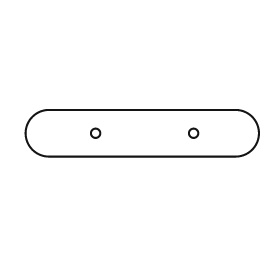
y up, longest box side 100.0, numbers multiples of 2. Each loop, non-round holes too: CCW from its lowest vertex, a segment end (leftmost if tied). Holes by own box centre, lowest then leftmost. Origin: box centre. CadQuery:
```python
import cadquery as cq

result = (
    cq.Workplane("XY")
    .moveTo(-40.0, -10.0)
    .lineTo(40.0, -10.0)
    .threePointArc((50.0, 0.0), (40.0, 10.0))
    .lineTo(-40.0, 10.0)
    .threePointArc((-50.0, 0.0), (-40.0, -10.0))
    .close()
    .moveTo(-20.0, 0.0)
    .circle(2.0)
    .moveTo(22.0, 0.0)
    .circle(2.0)
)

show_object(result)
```